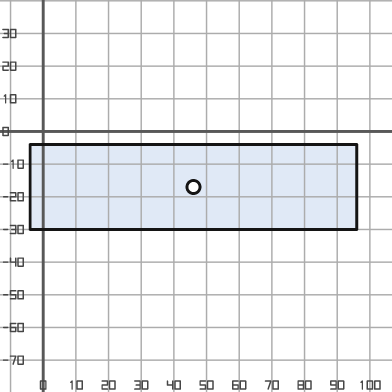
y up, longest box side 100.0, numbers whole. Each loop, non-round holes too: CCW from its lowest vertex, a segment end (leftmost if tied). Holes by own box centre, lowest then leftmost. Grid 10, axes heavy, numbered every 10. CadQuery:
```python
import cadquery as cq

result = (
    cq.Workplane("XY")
    .moveTo(-4.0, -30.0)
    .lineTo(96.0, -30.0)
    .lineTo(96.0, -4.0)
    .lineTo(-4.0, -4.0)
    .close()
    .moveTo(46.0, -17.0)
    .circle(2.0)
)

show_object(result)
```